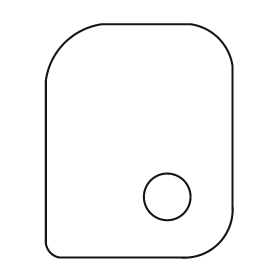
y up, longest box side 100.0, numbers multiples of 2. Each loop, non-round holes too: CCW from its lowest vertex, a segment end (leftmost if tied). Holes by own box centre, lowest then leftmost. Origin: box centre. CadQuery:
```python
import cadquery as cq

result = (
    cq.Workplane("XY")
    .moveTo(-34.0, -50.0)
    .lineTo(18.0, -50.0)
    .threePointArc((34.0, -44.0), (40.0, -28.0))
    .lineTo(40.0, 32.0)
    .threePointArc((34.0, 44.0), (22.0, 50.0))
    .lineTo(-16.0, 50.0)
    .threePointArc((-32.0, 42.0), (-40.0, 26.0))
    .lineTo(-40.0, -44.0)
    .threePointArc((-38.0, -48.0), (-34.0, -50.0))
    .close()
    .moveTo(12.0, -24.0)
    .circle(10.0)
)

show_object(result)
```